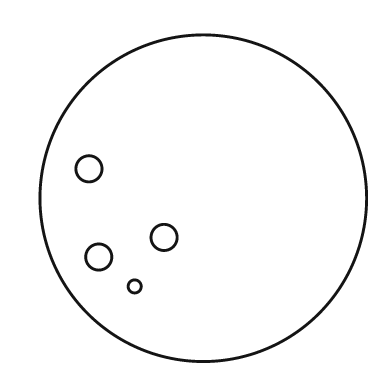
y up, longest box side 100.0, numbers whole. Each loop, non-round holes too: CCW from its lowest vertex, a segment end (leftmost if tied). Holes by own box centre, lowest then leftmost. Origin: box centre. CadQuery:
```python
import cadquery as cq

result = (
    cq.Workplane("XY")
    .moveTo(0.0, 0.0)
    .circle(50.0)
    .moveTo(-21.0, -27.0)
    .circle(2.0)
    .moveTo(-32.0, -18.0)
    .circle(4.0)
    .moveTo(-12.0, -12.0)
    .circle(4.0)
    .moveTo(-35.0, 9.0)
    .circle(4.0)
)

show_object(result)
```